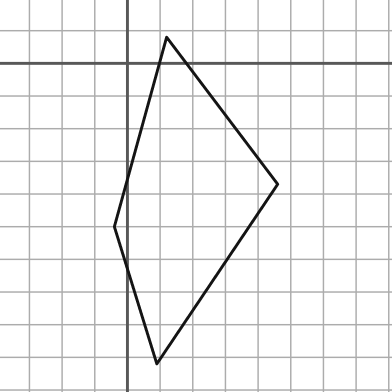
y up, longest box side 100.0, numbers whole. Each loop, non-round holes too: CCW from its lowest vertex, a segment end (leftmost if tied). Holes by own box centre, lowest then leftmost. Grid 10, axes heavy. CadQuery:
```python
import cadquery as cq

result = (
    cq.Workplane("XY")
    .moveTo(9.0, -92.0)
    .lineTo(46.0, -37.0)
    .lineTo(12.0, 8.0)
    .lineTo(-4.0, -50.0)
    .close()
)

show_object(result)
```